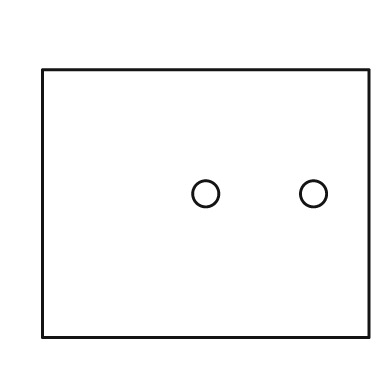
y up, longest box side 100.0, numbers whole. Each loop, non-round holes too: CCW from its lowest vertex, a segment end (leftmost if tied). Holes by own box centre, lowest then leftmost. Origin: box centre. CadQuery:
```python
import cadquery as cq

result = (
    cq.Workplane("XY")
    .moveTo(-50.0, -41.0)
    .lineTo(50.0, -41.0)
    .lineTo(50.0, 41.0)
    .lineTo(-50.0, 41.0)
    .close()
    .moveTo(0.0, 3.0)
    .circle(4.0)
    .moveTo(33.0, 3.0)
    .circle(4.0)
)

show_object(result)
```